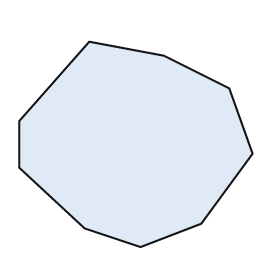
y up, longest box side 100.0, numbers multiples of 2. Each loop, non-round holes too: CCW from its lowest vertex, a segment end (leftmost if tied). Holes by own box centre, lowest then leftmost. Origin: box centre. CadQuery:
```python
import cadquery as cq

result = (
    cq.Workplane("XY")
    .moveTo(2.0, -44.0)
    .lineTo(28.0, -34.0)
    .lineTo(50.0, -4.0)
    .lineTo(40.0, 24.0)
    .lineTo(12.0, 38.0)
    .lineTo(-20.0, 44.0)
    .lineTo(-50.0, 10.0)
    .lineTo(-50.0, -10.0)
    .lineTo(-22.0, -36.0)
    .close()
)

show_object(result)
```